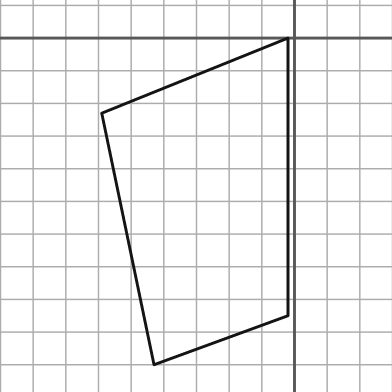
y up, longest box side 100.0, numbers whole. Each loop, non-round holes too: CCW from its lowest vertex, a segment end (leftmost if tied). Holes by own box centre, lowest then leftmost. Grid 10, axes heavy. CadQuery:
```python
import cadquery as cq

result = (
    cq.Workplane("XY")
    .moveTo(-43.0, -100.0)
    .lineTo(-2.0, -85.0)
    .lineTo(-2.0, 0.0)
    .lineTo(-59.0, -23.0)
    .close()
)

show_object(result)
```